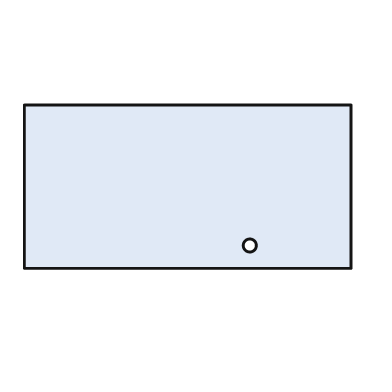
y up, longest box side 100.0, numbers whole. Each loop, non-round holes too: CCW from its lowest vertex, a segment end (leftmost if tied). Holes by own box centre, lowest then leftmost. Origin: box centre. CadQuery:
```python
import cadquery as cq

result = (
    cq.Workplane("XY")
    .moveTo(-50.0, -25.0)
    .lineTo(50.0, -25.0)
    .lineTo(50.0, 25.0)
    .lineTo(-50.0, 25.0)
    .close()
    .moveTo(19.0, -18.0)
    .circle(2.0)
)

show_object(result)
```